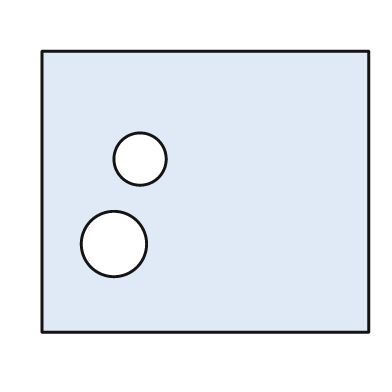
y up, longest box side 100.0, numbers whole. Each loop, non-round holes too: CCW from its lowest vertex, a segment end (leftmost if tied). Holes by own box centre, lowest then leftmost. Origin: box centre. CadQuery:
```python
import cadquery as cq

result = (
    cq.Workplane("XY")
    .moveTo(-50.0, -43.0)
    .lineTo(50.0, -43.0)
    .lineTo(50.0, 43.0)
    .lineTo(-50.0, 43.0)
    .close()
    .moveTo(-28.0, -16.0)
    .circle(10.0)
    .moveTo(-20.0, 10.0)
    .circle(8.0)
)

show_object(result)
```